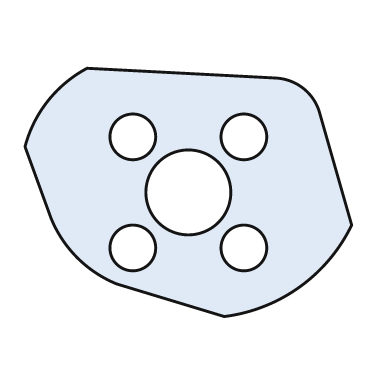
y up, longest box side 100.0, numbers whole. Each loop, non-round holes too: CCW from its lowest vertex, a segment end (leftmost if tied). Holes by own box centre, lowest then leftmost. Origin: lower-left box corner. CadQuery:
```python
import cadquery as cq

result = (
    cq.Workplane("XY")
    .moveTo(61.0, 0.0)
    .threePointArc((84.0, 9.0), (100.0, 28.0))
    .lineTo(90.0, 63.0)
    .threePointArc((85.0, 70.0), (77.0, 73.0))
    .lineTo(19.0, 76.0)
    .threePointArc((7.0, 66.0), (0.0, 52.0))
    .lineTo(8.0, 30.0)
    .threePointArc((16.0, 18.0), (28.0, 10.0))
    .close()
    .moveTo(33.0, 21.0)
    .circle(7.0)
    .moveTo(67.0, 21.0)
    .circle(7.0)
    .moveTo(50.0, 38.0)
    .circle(13.0)
    .moveTo(33.0, 55.0)
    .circle(7.0)
    .moveTo(67.0, 55.0)
    .circle(7.0)
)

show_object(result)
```